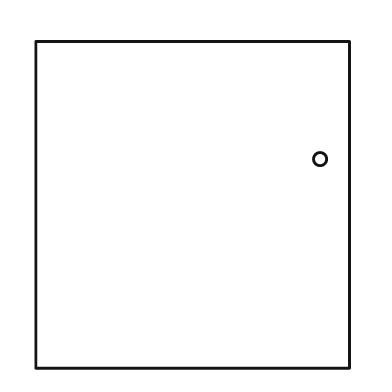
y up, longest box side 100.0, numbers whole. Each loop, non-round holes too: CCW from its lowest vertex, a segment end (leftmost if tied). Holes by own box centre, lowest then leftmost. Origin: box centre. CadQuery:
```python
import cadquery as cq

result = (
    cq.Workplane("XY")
    .moveTo(-48.0, -50.0)
    .lineTo(48.0, -50.0)
    .lineTo(48.0, 50.0)
    .lineTo(-48.0, 50.0)
    .close()
    .moveTo(39.0, 14.0)
    .circle(2.0)
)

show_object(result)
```